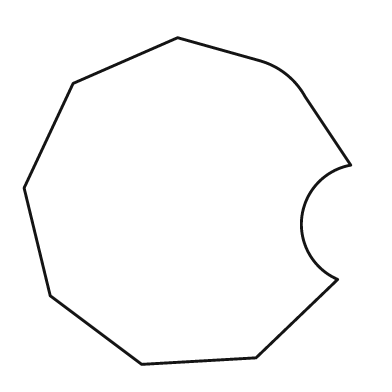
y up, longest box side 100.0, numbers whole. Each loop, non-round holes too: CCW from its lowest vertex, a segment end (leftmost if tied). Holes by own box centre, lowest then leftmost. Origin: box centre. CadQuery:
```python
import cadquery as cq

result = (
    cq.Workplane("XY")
    .moveTo(-14.0, -50.0)
    .lineTo(21.0, -48.0)
    .lineTo(46.0, -24.0)
    .threePointArc((35.0, -5.0), (50.0, 11.0))
    .lineTo(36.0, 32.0)
    .threePointArc((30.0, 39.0), (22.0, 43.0))
    .lineTo(-3.0, 50.0)
    .lineTo(-35.0, 36.0)
    .lineTo(-50.0, 4.0)
    .lineTo(-42.0, -29.0)
    .close()
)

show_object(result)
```